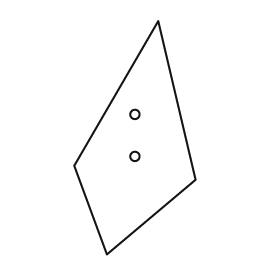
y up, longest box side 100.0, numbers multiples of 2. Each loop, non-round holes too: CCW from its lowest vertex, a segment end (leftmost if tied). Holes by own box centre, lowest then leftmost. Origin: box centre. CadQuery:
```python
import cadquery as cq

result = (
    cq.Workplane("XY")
    .moveTo(-12.0, -50.0)
    .lineTo(26.0, -18.0)
    .lineTo(10.0, 50.0)
    .lineTo(-26.0, -12.0)
    .close()
    .moveTo(0.0, -8.0)
    .circle(2.0)
    .moveTo(0.0, 10.0)
    .circle(2.0)
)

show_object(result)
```